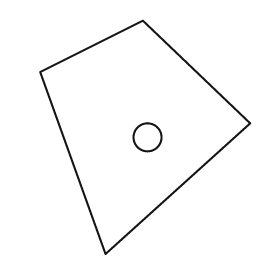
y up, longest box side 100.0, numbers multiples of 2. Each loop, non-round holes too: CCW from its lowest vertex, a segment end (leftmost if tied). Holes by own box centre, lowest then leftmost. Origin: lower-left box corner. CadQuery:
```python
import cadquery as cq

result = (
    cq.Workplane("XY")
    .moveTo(28.0, 0.0)
    .lineTo(90.0, 56.0)
    .lineTo(44.0, 100.0)
    .lineTo(0.0, 78.0)
    .close()
    .moveTo(46.0, 50.0)
    .circle(6.0)
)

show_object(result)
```